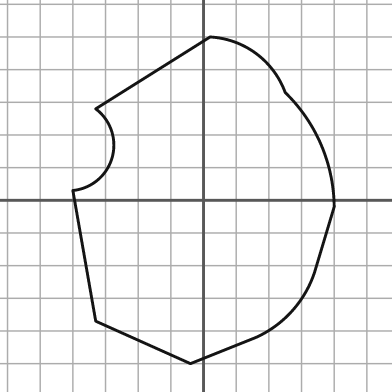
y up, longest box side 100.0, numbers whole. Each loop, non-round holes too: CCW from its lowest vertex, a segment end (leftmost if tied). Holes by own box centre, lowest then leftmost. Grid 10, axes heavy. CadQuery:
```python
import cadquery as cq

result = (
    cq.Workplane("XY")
    .moveTo(-4.0, -50.0)
    .lineTo(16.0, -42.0)
    .threePointArc((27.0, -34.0), (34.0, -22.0))
    .lineTo(40.0, -2.0)
    .threePointArc((36.0, 17.0), (25.0, 33.0))
    .threePointArc((16.0, 45.0), (2.0, 50.0))
    .lineTo(-33.0, 28.0)
    .threePointArc((-28.0, 13.0), (-40.0, 3.0))
    .lineTo(-33.0, -37.0)
    .close()
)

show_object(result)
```